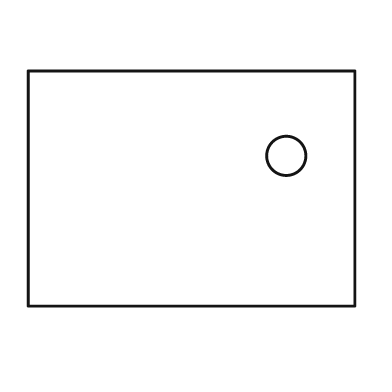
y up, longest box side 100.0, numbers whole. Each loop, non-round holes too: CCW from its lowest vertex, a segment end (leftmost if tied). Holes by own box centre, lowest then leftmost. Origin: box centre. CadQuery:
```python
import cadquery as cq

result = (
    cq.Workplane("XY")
    .moveTo(-50.0, -36.0)
    .lineTo(50.0, -36.0)
    .lineTo(50.0, 36.0)
    .lineTo(-50.0, 36.0)
    .close()
    .moveTo(29.0, 10.0)
    .circle(6.0)
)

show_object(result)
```